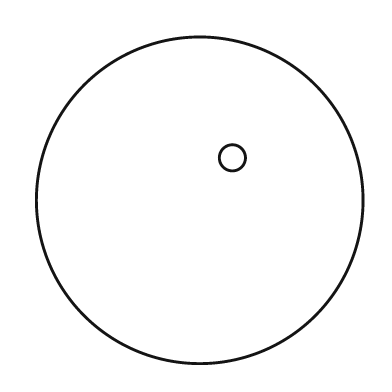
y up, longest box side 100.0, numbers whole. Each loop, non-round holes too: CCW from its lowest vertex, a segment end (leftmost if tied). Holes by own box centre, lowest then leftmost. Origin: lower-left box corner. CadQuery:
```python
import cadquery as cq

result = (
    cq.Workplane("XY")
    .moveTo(50.0, 50.0)
    .circle(50.0)
    .moveTo(60.0, 63.0)
    .circle(4.0)
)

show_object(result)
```